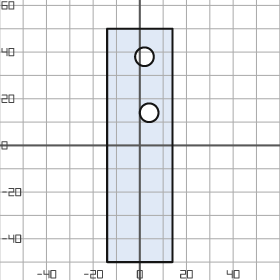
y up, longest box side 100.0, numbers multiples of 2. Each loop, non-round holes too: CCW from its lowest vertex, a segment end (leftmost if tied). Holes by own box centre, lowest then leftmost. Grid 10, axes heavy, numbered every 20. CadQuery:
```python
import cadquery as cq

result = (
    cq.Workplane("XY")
    .moveTo(-14.0, -50.0)
    .lineTo(14.0, -50.0)
    .lineTo(14.0, 50.0)
    .lineTo(-14.0, 50.0)
    .close()
    .moveTo(4.0, 14.0)
    .circle(4.0)
    .moveTo(2.0, 38.0)
    .circle(4.0)
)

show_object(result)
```